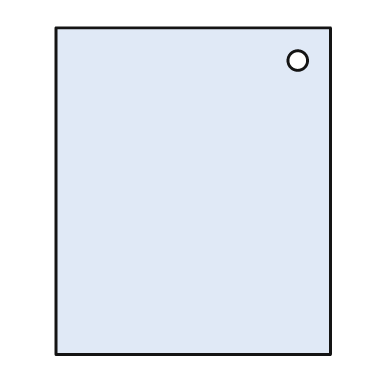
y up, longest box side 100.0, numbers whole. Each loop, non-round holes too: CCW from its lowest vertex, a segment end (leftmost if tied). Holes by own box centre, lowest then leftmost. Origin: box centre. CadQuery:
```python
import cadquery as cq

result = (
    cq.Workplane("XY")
    .moveTo(-42.0, -50.0)
    .lineTo(42.0, -50.0)
    .lineTo(42.0, 50.0)
    .lineTo(-42.0, 50.0)
    .close()
    .moveTo(32.0, 40.0)
    .circle(3.0)
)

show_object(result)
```